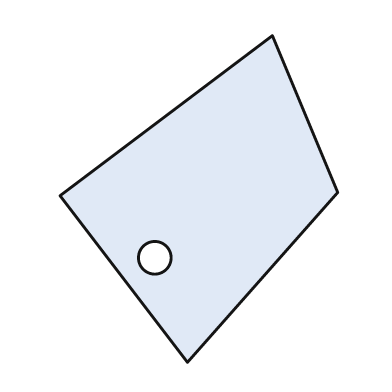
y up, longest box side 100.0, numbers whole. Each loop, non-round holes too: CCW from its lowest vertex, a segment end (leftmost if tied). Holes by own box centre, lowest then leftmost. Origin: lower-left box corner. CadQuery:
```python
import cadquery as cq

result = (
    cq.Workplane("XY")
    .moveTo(39.0, 0.0)
    .lineTo(85.0, 52.0)
    .lineTo(65.0, 100.0)
    .lineTo(0.0, 51.0)
    .close()
    .moveTo(29.0, 32.0)
    .circle(5.0)
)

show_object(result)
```